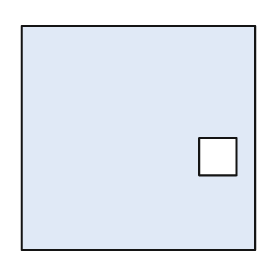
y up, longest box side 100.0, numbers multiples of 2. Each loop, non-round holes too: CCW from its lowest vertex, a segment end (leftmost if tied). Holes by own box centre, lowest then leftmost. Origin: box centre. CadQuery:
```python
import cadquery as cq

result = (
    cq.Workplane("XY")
    .moveTo(-50.0, -48.0)
    .lineTo(50.0, -48.0)
    .lineTo(50.0, 48.0)
    .lineTo(-50.0, 48.0)
    .close()
    .moveTo(26.0, -16.0)
    .lineTo(42.0, -16.0)
    .lineTo(42.0, 0.0)
    .lineTo(26.0, 0.0)
    .close()
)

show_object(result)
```